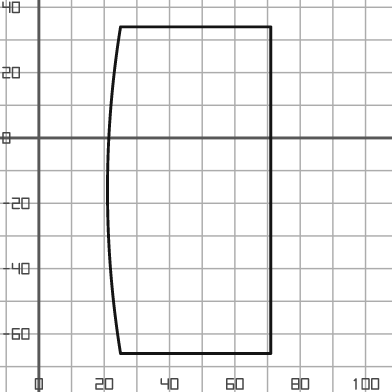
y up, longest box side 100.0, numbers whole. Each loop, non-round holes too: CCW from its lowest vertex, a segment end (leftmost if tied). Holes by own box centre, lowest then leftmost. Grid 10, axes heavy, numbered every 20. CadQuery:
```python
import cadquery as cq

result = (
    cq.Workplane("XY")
    .moveTo(25.0, -66.0)
    .lineTo(71.0, -66.0)
    .lineTo(71.0, 34.0)
    .lineTo(25.0, 34.0)
    .threePointArc((21.0, -16.0), (25.0, -66.0))
    .close()
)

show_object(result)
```